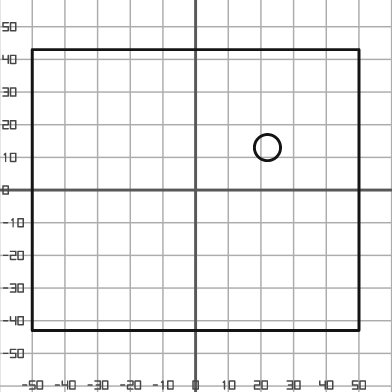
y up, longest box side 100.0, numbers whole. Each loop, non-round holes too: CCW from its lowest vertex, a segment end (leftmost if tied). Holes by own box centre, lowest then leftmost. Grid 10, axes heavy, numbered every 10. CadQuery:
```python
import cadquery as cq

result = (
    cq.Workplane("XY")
    .moveTo(-50.0, -43.0)
    .lineTo(50.0, -43.0)
    .lineTo(50.0, 43.0)
    .lineTo(-50.0, 43.0)
    .close()
    .moveTo(22.0, 13.0)
    .circle(4.0)
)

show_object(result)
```